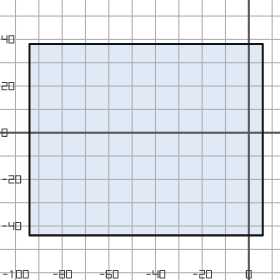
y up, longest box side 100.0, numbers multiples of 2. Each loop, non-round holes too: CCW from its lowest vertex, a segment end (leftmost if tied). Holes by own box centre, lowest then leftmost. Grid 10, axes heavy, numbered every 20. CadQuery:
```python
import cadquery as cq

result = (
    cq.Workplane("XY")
    .moveTo(-94.0, -44.0)
    .lineTo(6.0, -44.0)
    .lineTo(6.0, 38.0)
    .lineTo(-94.0, 38.0)
    .close()
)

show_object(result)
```